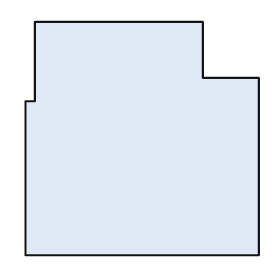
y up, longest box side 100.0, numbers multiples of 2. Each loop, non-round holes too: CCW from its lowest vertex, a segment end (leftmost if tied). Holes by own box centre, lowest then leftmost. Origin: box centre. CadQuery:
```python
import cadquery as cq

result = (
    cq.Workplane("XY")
    .moveTo(-50.0, -50.0)
    .lineTo(50.0, -50.0)
    .lineTo(50.0, 26.0)
    .lineTo(26.0, 26.0)
    .lineTo(26.0, 50.0)
    .lineTo(-46.0, 50.0)
    .lineTo(-46.0, 16.0)
    .lineTo(-50.0, 16.0)
    .close()
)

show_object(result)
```